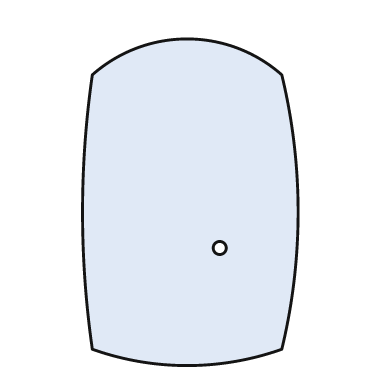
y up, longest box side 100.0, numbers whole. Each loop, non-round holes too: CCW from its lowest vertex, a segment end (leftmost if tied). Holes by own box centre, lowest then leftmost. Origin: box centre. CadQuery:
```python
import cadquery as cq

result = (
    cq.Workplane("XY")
    .moveTo(-30.0, -45.0)
    .threePointArc((-1.0, -50.0), (28.0, -45.0))
    .threePointArc((33.0, -3.0), (28.0, 39.0))
    .threePointArc((-1.0, 50.0), (-30.0, 39.0))
    .threePointArc((-33.0, -3.0), (-30.0, -45.0))
    .close()
    .moveTo(9.0, -14.0)
    .circle(2.0)
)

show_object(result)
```